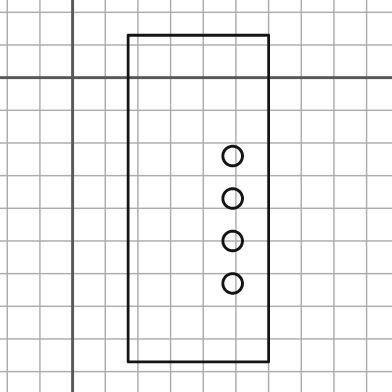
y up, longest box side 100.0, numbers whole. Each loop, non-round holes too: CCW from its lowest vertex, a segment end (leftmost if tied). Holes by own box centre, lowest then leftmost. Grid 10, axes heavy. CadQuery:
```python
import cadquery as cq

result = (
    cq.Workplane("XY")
    .moveTo(17.0, -87.0)
    .lineTo(60.0, -87.0)
    .lineTo(60.0, 13.0)
    .lineTo(17.0, 13.0)
    .close()
    .moveTo(49.0, -63.0)
    .circle(3.0)
    .moveTo(49.0, -50.0)
    .circle(3.0)
    .moveTo(49.0, -37.0)
    .circle(3.0)
    .moveTo(49.0, -24.0)
    .circle(3.0)
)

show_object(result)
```